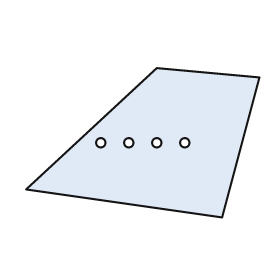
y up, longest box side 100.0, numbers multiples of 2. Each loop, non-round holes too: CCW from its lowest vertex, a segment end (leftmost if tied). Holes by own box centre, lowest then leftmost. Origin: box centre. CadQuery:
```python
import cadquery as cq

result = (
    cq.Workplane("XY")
    .moveTo(34.0, -32.0)
    .lineTo(50.0, 28.0)
    .lineTo(6.0, 32.0)
    .lineTo(-50.0, -20.0)
    .close()
    .moveTo(-18.0, 0.0)
    .circle(2.0)
    .moveTo(-6.0, 0.0)
    .circle(2.0)
    .moveTo(6.0, 0.0)
    .circle(2.0)
    .moveTo(18.0, 0.0)
    .circle(2.0)
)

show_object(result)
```